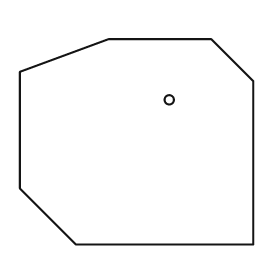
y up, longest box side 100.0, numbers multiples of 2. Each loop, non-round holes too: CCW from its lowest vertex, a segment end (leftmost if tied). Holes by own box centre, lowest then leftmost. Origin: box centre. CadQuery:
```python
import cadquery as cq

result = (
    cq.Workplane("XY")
    .moveTo(-26.0, -44.0)
    .lineTo(50.0, -44.0)
    .lineTo(50.0, 26.0)
    .lineTo(32.0, 44.0)
    .lineTo(-12.0, 44.0)
    .lineTo(-50.0, 30.0)
    .lineTo(-50.0, -20.0)
    .close()
    .moveTo(14.0, 18.0)
    .circle(2.0)
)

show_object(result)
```